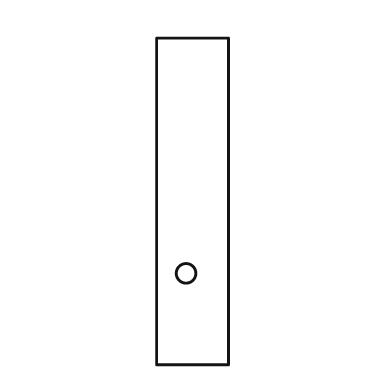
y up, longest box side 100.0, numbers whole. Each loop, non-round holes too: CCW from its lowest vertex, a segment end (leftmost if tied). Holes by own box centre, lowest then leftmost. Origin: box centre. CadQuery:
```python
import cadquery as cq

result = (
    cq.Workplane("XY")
    .moveTo(-11.0, -50.0)
    .lineTo(11.0, -50.0)
    .lineTo(11.0, 50.0)
    .lineTo(-11.0, 50.0)
    .close()
    .moveTo(-2.0, -22.0)
    .circle(3.0)
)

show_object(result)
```